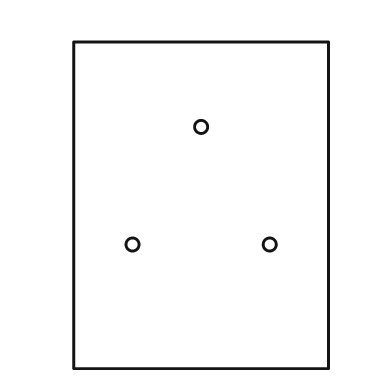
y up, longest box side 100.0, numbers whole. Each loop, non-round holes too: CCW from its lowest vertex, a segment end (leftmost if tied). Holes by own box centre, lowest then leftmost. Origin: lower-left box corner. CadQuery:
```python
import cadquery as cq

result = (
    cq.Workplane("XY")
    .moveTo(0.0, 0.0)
    .lineTo(78.0, 0.0)
    .lineTo(78.0, 100.0)
    .lineTo(0.0, 100.0)
    .close()
    .moveTo(18.0, 38.0)
    .circle(2.0)
    .moveTo(60.0, 38.0)
    .circle(2.0)
    .moveTo(39.0, 74.0)
    .circle(2.0)
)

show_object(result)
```